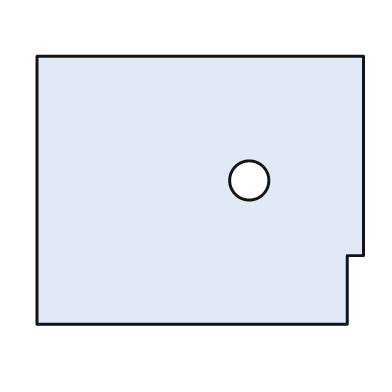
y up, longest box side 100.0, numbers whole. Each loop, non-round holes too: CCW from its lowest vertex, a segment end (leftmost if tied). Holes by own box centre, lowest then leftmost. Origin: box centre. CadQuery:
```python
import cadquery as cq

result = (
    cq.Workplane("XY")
    .moveTo(-50.0, -41.0)
    .lineTo(45.0, -41.0)
    .lineTo(45.0, -20.0)
    .lineTo(50.0, -20.0)
    .lineTo(50.0, 41.0)
    .lineTo(-50.0, 41.0)
    .close()
    .moveTo(15.0, 3.0)
    .circle(6.0)
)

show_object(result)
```